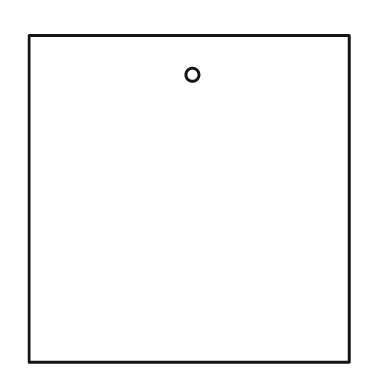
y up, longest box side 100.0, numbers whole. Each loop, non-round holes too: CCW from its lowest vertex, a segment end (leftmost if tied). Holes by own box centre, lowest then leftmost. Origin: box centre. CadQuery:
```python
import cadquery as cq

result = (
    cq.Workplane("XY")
    .moveTo(-49.0, -50.0)
    .lineTo(49.0, -50.0)
    .lineTo(49.0, 50.0)
    .lineTo(-49.0, 50.0)
    .close()
    .moveTo(1.0, 38.0)
    .circle(2.0)
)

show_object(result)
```